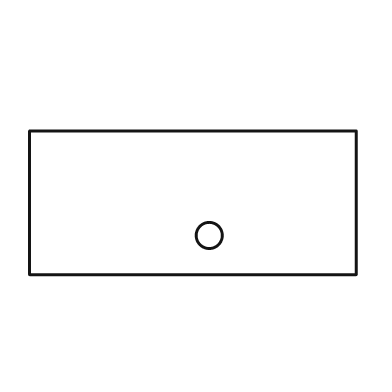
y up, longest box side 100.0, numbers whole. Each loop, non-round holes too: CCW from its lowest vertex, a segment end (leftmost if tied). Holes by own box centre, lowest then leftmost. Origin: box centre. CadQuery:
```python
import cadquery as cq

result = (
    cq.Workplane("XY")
    .moveTo(-50.0, -22.0)
    .lineTo(50.0, -22.0)
    .lineTo(50.0, 22.0)
    .lineTo(-50.0, 22.0)
    .close()
    .moveTo(5.0, -10.0)
    .circle(4.0)
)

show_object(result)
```